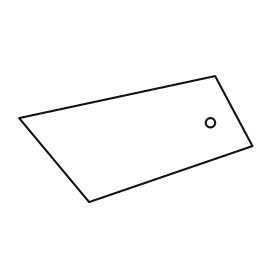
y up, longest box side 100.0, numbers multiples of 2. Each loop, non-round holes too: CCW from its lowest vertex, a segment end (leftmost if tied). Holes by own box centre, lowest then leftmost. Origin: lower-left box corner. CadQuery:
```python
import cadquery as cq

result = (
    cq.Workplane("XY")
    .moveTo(30.0, 0.0)
    .lineTo(100.0, 24.0)
    .lineTo(84.0, 54.0)
    .lineTo(0.0, 36.0)
    .close()
    .moveTo(82.0, 34.0)
    .circle(2.0)
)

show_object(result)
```